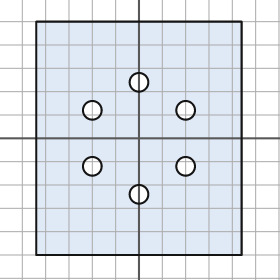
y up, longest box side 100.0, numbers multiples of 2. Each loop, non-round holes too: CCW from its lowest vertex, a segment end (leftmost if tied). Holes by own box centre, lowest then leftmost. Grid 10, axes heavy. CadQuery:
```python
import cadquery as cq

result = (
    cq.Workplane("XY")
    .moveTo(-44.0, -50.0)
    .lineTo(44.0, -50.0)
    .lineTo(44.0, 50.0)
    .lineTo(-44.0, 50.0)
    .close()
    .moveTo(0.0, -24.0)
    .circle(4.0)
    .moveTo(-20.0, -12.0)
    .circle(4.0)
    .moveTo(20.0, -12.0)
    .circle(4.0)
    .moveTo(-20.0, 12.0)
    .circle(4.0)
    .moveTo(20.0, 12.0)
    .circle(4.0)
    .moveTo(0.0, 24.0)
    .circle(4.0)
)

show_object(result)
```